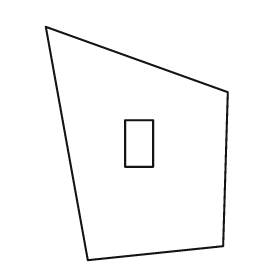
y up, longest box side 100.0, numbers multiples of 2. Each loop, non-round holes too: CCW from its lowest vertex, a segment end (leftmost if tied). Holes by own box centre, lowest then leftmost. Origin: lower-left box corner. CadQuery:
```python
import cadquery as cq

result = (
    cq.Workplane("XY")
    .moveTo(18.0, 0.0)
    .lineTo(76.0, 6.0)
    .lineTo(78.0, 72.0)
    .lineTo(0.0, 100.0)
    .close()
    .moveTo(34.0, 40.0)
    .lineTo(46.0, 40.0)
    .lineTo(46.0, 60.0)
    .lineTo(34.0, 60.0)
    .close()
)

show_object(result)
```